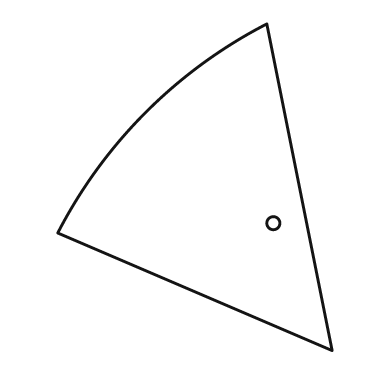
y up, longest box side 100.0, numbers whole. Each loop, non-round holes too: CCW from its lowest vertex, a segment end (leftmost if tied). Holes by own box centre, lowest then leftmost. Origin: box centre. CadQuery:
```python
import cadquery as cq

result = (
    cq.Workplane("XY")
    .moveTo(42.0, -50.0)
    .lineTo(22.0, 50.0)
    .threePointArc((-15.0, 23.0), (-42.0, -14.0))
    .close()
    .moveTo(24.0, -11.0)
    .circle(2.0)
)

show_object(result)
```